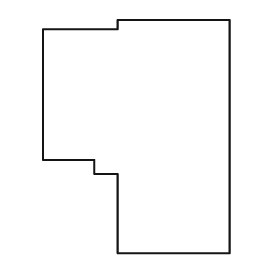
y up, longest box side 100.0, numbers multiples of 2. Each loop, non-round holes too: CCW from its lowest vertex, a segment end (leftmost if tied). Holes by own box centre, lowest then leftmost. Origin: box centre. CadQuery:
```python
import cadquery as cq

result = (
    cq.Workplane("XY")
    .moveTo(-8.0, -50.0)
    .lineTo(40.0, -50.0)
    .lineTo(40.0, 50.0)
    .lineTo(-8.0, 50.0)
    .lineTo(-8.0, 46.0)
    .lineTo(-40.0, 46.0)
    .lineTo(-40.0, -10.0)
    .lineTo(-18.0, -10.0)
    .lineTo(-18.0, -16.0)
    .lineTo(-8.0, -16.0)
    .close()
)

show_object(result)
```